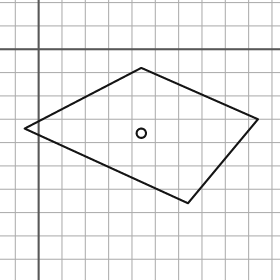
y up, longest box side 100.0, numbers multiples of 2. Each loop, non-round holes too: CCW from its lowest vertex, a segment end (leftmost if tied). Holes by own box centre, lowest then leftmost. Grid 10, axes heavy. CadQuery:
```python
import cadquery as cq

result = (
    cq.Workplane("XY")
    .moveTo(64.0, -66.0)
    .lineTo(94.0, -30.0)
    .lineTo(44.0, -8.0)
    .lineTo(-6.0, -34.0)
    .close()
    .moveTo(44.0, -36.0)
    .circle(2.0)
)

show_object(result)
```